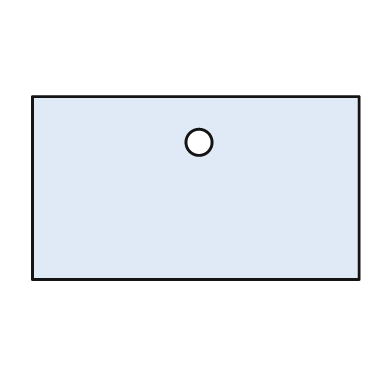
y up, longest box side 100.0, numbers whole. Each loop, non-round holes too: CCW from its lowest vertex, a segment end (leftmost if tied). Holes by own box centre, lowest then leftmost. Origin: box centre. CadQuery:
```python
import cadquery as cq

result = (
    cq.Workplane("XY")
    .moveTo(-50.0, -28.0)
    .lineTo(50.0, -28.0)
    .lineTo(50.0, 28.0)
    .lineTo(-50.0, 28.0)
    .close()
    .moveTo(1.0, 14.0)
    .circle(4.0)
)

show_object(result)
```